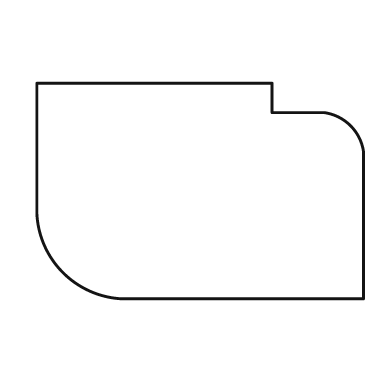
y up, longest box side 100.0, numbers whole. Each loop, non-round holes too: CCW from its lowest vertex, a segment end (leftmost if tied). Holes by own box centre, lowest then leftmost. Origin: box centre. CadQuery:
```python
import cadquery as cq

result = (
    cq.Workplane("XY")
    .moveTo(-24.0, -33.0)
    .lineTo(50.0, -33.0)
    .lineTo(50.0, 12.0)
    .threePointArc((46.0, 20.0), (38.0, 24.0))
    .lineTo(22.0, 24.0)
    .lineTo(22.0, 33.0)
    .lineTo(-50.0, 33.0)
    .lineTo(-50.0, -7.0)
    .threePointArc((-42.0, -25.0), (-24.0, -33.0))
    .close()
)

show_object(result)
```